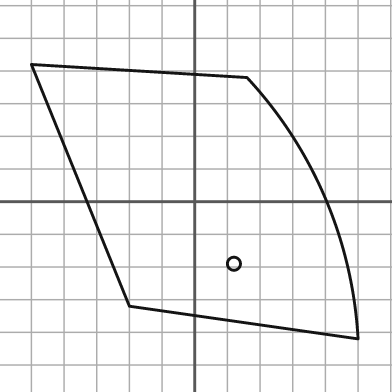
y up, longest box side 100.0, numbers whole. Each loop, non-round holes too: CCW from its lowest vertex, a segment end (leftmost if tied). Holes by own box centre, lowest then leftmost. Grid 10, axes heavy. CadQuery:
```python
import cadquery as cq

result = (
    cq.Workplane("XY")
    .moveTo(50.0, -42.0)
    .threePointArc((40.0, 1.0), (16.0, 38.0))
    .lineTo(-50.0, 42.0)
    .lineTo(-20.0, -32.0)
    .close()
    .moveTo(12.0, -19.0)
    .circle(2.0)
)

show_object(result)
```